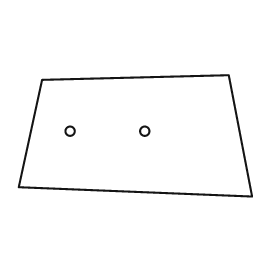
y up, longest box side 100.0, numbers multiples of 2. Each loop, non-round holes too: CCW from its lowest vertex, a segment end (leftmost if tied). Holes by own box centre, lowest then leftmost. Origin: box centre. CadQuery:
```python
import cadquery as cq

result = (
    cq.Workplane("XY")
    .moveTo(50.0, -26.0)
    .lineTo(40.0, 26.0)
    .lineTo(-40.0, 24.0)
    .lineTo(-50.0, -22.0)
    .close()
    .moveTo(-28.0, 2.0)
    .circle(2.0)
    .moveTo(4.0, 2.0)
    .circle(2.0)
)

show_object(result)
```